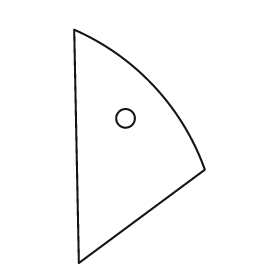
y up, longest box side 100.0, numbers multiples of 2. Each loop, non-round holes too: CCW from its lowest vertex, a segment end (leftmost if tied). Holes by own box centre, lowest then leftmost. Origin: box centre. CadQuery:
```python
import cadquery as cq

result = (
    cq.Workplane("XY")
    .moveTo(-26.0, -50.0)
    .lineTo(28.0, -10.0)
    .threePointArc((6.0, 26.0), (-28.0, 50.0))
    .close()
    .moveTo(-6.0, 12.0)
    .circle(4.0)
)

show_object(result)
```